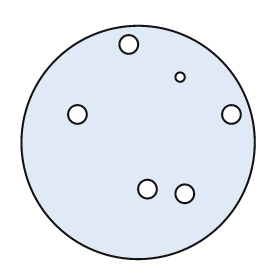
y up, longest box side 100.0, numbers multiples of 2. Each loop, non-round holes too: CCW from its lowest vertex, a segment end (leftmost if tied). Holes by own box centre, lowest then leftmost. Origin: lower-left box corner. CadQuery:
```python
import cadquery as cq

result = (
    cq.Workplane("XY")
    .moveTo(50.0, 50.0)
    .circle(50.0)
    .moveTo(70.0, 28.0)
    .circle(4.0)
    .moveTo(54.0, 30.0)
    .circle(4.0)
    .moveTo(24.0, 62.0)
    .circle(4.0)
    .moveTo(90.0, 62.0)
    .circle(4.0)
    .moveTo(68.0, 78.0)
    .circle(2.0)
    .moveTo(46.0, 92.0)
    .circle(4.0)
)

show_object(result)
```